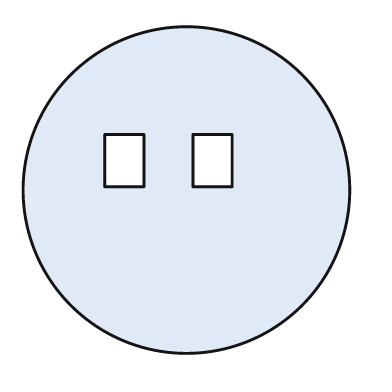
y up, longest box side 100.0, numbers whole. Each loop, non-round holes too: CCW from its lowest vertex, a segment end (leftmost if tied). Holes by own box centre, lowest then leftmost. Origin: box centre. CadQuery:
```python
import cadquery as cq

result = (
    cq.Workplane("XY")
    .moveTo(0.0, 0.0)
    .circle(50.0)
    .moveTo(-25.0, 1.0)
    .lineTo(-13.0, 1.0)
    .lineTo(-13.0, 17.0)
    .lineTo(-25.0, 17.0)
    .close()
    .moveTo(2.0, 1.0)
    .lineTo(14.0, 1.0)
    .lineTo(14.0, 17.0)
    .lineTo(2.0, 17.0)
    .close()
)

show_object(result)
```